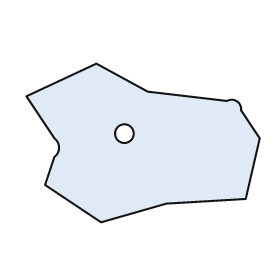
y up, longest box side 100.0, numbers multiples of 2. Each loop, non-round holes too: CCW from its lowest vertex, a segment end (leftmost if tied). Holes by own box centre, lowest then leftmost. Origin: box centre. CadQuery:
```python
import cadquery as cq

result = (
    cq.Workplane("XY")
    .moveTo(-18.0, -34.0)
    .lineTo(10.0, -26.0)
    .lineTo(44.0, -24.0)
    .lineTo(50.0, 2.0)
    .lineTo(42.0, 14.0)
    .threePointArc((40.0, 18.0), (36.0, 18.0))
    .lineTo(2.0, 22.0)
    .lineTo(-20.0, 34.0)
    .lineTo(-50.0, 20.0)
    .lineTo(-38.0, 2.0)
    .threePointArc((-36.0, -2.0), (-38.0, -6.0))
    .lineTo(-42.0, -18.0)
    .close()
    .moveTo(-8.0, 4.0)
    .circle(4.0)
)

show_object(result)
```